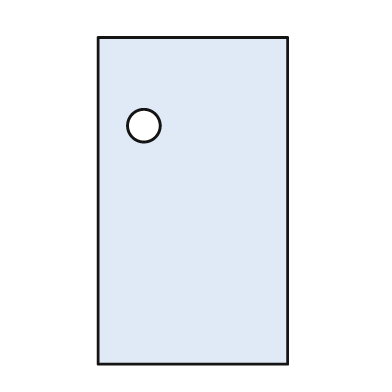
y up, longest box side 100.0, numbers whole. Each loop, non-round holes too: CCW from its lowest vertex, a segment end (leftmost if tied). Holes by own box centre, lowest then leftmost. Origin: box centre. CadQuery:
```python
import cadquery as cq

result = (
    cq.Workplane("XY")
    .moveTo(-29.0, -50.0)
    .lineTo(29.0, -50.0)
    .lineTo(29.0, 50.0)
    .lineTo(-29.0, 50.0)
    .close()
    .moveTo(-15.0, 23.0)
    .circle(5.0)
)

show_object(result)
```